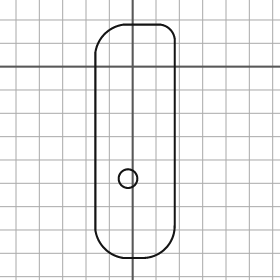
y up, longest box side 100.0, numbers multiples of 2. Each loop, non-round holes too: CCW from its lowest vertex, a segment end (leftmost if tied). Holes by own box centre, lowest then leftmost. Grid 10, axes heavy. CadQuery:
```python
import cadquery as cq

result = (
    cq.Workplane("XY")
    .moveTo(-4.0, -82.0)
    .lineTo(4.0, -82.0)
    .threePointArc((14.0, -78.0), (18.0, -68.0))
    .lineTo(18.0, 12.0)
    .threePointArc((16.0, 16.0), (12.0, 18.0))
    .lineTo(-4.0, 18.0)
    .threePointArc((-12.0, 14.0), (-16.0, 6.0))
    .lineTo(-16.0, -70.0)
    .threePointArc((-12.0, -78.0), (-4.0, -82.0))
    .close()
    .moveTo(-2.0, -48.0)
    .circle(4.0)
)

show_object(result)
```